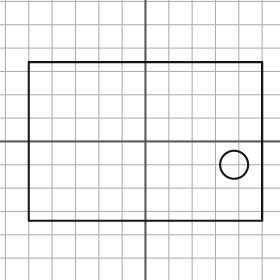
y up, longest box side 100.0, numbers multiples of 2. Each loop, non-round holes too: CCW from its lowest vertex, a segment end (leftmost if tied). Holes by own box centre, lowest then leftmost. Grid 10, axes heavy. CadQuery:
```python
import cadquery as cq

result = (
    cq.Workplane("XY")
    .moveTo(-50.0, -34.0)
    .lineTo(50.0, -34.0)
    .lineTo(50.0, 34.0)
    .lineTo(-50.0, 34.0)
    .close()
    .moveTo(38.0, -10.0)
    .circle(6.0)
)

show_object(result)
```